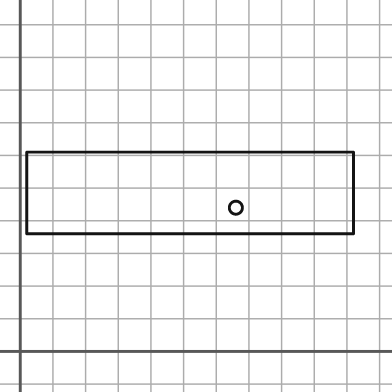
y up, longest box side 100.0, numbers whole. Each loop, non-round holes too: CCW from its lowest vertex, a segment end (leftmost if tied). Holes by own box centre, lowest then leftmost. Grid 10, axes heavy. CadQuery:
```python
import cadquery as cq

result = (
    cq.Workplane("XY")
    .moveTo(2.0, 36.0)
    .lineTo(102.0, 36.0)
    .lineTo(102.0, 61.0)
    .lineTo(2.0, 61.0)
    .close()
    .moveTo(66.0, 44.0)
    .circle(2.0)
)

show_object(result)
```